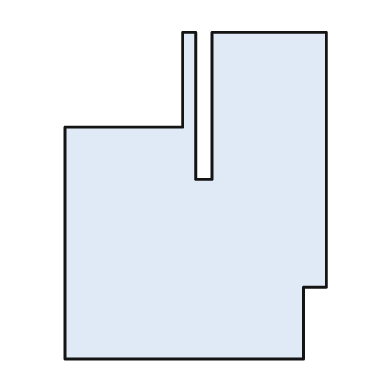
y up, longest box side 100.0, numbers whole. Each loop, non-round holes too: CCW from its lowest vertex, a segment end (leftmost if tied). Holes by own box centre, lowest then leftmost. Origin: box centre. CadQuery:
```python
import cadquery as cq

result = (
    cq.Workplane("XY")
    .moveTo(-40.0, -50.0)
    .lineTo(33.0, -50.0)
    .lineTo(33.0, -28.0)
    .lineTo(40.0, -28.0)
    .lineTo(40.0, 50.0)
    .lineTo(5.0, 50.0)
    .lineTo(5.0, 5.0)
    .lineTo(0.0, 5.0)
    .lineTo(0.0, 50.0)
    .lineTo(-4.0, 50.0)
    .lineTo(-4.0, 21.0)
    .lineTo(-40.0, 21.0)
    .close()
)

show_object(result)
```